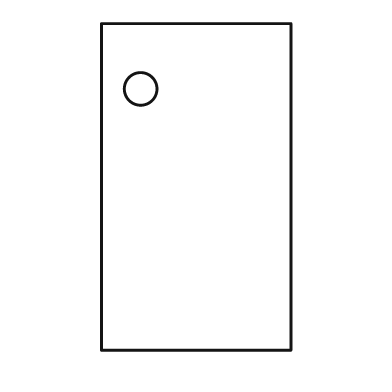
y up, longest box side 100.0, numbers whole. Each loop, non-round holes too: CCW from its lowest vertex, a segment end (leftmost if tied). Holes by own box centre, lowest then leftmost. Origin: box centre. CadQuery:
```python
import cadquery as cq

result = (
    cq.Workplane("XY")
    .moveTo(-29.0, -50.0)
    .lineTo(29.0, -50.0)
    .lineTo(29.0, 50.0)
    .lineTo(-29.0, 50.0)
    .close()
    .moveTo(-17.0, 30.0)
    .circle(5.0)
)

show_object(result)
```